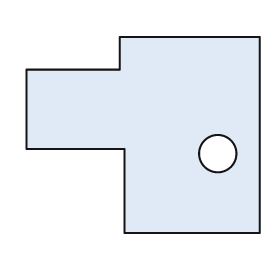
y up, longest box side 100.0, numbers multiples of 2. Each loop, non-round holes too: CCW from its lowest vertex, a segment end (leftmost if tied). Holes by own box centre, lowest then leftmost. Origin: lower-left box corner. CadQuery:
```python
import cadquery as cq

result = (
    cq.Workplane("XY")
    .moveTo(42.0, 0.0)
    .lineTo(100.0, 0.0)
    .lineTo(100.0, 84.0)
    .lineTo(40.0, 84.0)
    .lineTo(40.0, 70.0)
    .lineTo(0.0, 70.0)
    .lineTo(0.0, 36.0)
    .lineTo(42.0, 36.0)
    .close()
    .moveTo(82.0, 34.0)
    .circle(8.0)
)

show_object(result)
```